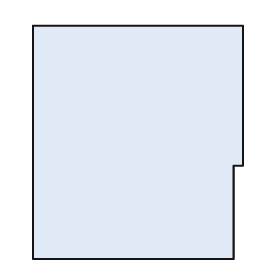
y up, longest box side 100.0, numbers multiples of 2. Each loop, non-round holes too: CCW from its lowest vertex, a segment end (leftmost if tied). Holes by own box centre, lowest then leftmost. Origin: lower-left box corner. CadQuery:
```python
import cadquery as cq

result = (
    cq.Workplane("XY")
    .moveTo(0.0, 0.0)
    .lineTo(86.0, 0.0)
    .lineTo(86.0, 40.0)
    .lineTo(90.0, 40.0)
    .lineTo(90.0, 100.0)
    .lineTo(0.0, 100.0)
    .close()
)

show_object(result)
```